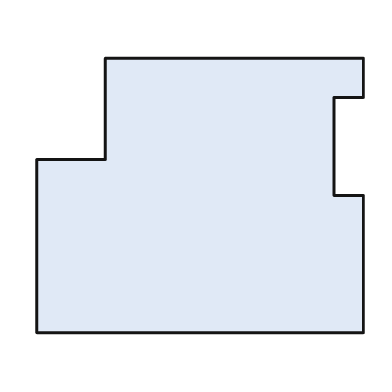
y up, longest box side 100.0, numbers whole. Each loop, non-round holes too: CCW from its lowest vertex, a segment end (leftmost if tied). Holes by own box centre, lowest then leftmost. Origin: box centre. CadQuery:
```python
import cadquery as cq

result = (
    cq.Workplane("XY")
    .moveTo(-50.0, -42.0)
    .lineTo(50.0, -42.0)
    .lineTo(50.0, 0.0)
    .lineTo(41.0, 0.0)
    .lineTo(41.0, 30.0)
    .lineTo(50.0, 30.0)
    .lineTo(50.0, 42.0)
    .lineTo(-29.0, 42.0)
    .lineTo(-29.0, 11.0)
    .lineTo(-50.0, 11.0)
    .close()
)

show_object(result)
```